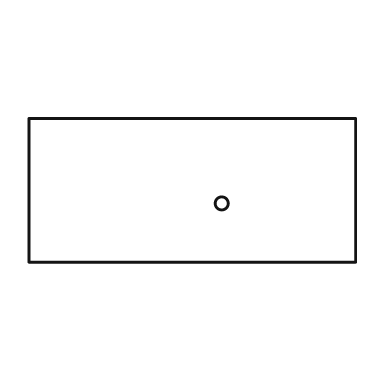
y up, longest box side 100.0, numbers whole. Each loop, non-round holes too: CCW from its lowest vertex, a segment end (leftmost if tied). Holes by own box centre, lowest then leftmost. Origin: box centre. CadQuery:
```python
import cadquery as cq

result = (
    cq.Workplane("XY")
    .moveTo(-50.0, -22.0)
    .lineTo(50.0, -22.0)
    .lineTo(50.0, 22.0)
    .lineTo(-50.0, 22.0)
    .close()
    .moveTo(9.0, -4.0)
    .circle(2.0)
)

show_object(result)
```